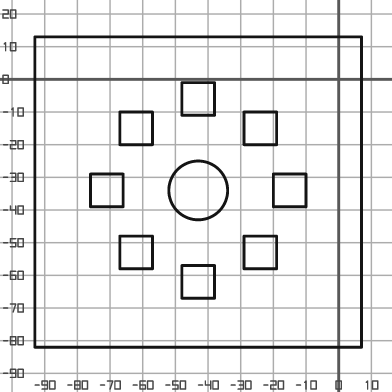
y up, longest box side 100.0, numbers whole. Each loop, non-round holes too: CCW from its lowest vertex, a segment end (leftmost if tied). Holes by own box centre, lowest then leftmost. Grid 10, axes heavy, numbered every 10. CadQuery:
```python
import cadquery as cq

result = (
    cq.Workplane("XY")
    .moveTo(-93.0, -82.0)
    .lineTo(7.0, -82.0)
    .lineTo(7.0, 13.0)
    .lineTo(-93.0, 13.0)
    .close()
    .moveTo(-48.0, -67.0)
    .lineTo(-38.0, -67.0)
    .lineTo(-38.0, -57.0)
    .lineTo(-48.0, -57.0)
    .close()
    .moveTo(-67.0, -58.0)
    .lineTo(-57.0, -58.0)
    .lineTo(-57.0, -48.0)
    .lineTo(-67.0, -48.0)
    .close()
    .moveTo(-29.0, -58.0)
    .lineTo(-19.0, -58.0)
    .lineTo(-19.0, -48.0)
    .lineTo(-29.0, -48.0)
    .close()
    .moveTo(-76.0, -39.0)
    .lineTo(-66.0, -39.0)
    .lineTo(-66.0, -29.0)
    .lineTo(-76.0, -29.0)
    .close()
    .moveTo(-43.0, -34.0)
    .circle(9.0)
    .moveTo(-20.0, -39.0)
    .lineTo(-10.0, -39.0)
    .lineTo(-10.0, -29.0)
    .lineTo(-20.0, -29.0)
    .close()
    .moveTo(-67.0, -20.0)
    .lineTo(-57.0, -20.0)
    .lineTo(-57.0, -10.0)
    .lineTo(-67.0, -10.0)
    .close()
    .moveTo(-29.0, -20.0)
    .lineTo(-19.0, -20.0)
    .lineTo(-19.0, -10.0)
    .lineTo(-29.0, -10.0)
    .close()
    .moveTo(-48.0, -11.0)
    .lineTo(-38.0, -11.0)
    .lineTo(-38.0, -1.0)
    .lineTo(-48.0, -1.0)
    .close()
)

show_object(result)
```